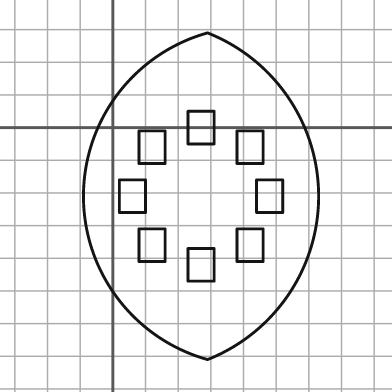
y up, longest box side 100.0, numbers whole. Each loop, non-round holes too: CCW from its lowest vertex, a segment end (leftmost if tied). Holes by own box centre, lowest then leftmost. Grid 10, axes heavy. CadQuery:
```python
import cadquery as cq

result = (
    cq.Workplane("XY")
    .moveTo(29.0, -71.0)
    .threePointArc((63.0, -21.0), (29.0, 29.0))
    .threePointArc((-9.0, -21.0), (29.0, -71.0))
    .close()
    .moveTo(23.0, -47.0)
    .lineTo(31.0, -47.0)
    .lineTo(31.0, -37.0)
    .lineTo(23.0, -37.0)
    .close()
    .moveTo(8.0, -41.0)
    .lineTo(16.0, -41.0)
    .lineTo(16.0, -31.0)
    .lineTo(8.0, -31.0)
    .close()
    .moveTo(38.0, -41.0)
    .lineTo(46.0, -41.0)
    .lineTo(46.0, -31.0)
    .lineTo(38.0, -31.0)
    .close()
    .moveTo(2.0, -26.0)
    .lineTo(10.0, -26.0)
    .lineTo(10.0, -16.0)
    .lineTo(2.0, -16.0)
    .close()
    .moveTo(44.0, -26.0)
    .lineTo(52.0, -26.0)
    .lineTo(52.0, -16.0)
    .lineTo(44.0, -16.0)
    .close()
    .moveTo(8.0, -11.0)
    .lineTo(16.0, -11.0)
    .lineTo(16.0, -1.0)
    .lineTo(8.0, -1.0)
    .close()
    .moveTo(38.0, -11.0)
    .lineTo(46.0, -11.0)
    .lineTo(46.0, -1.0)
    .lineTo(38.0, -1.0)
    .close()
    .moveTo(23.0, -5.0)
    .lineTo(31.0, -5.0)
    .lineTo(31.0, 5.0)
    .lineTo(23.0, 5.0)
    .close()
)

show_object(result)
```